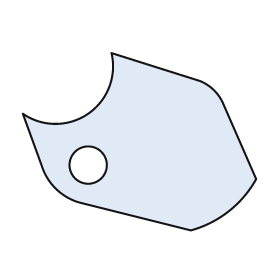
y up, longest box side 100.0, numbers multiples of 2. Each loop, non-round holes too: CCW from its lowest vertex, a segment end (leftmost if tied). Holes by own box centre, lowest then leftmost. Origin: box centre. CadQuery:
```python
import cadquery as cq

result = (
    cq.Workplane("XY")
    .moveTo(22.0, -38.0)
    .threePointArc((38.0, -30.0), (50.0, -16.0))
    .lineTo(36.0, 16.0)
    .threePointArc((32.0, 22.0), (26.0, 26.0))
    .lineTo(-12.0, 38.0)
    .threePointArc((-22.0, 12.0), (-50.0, 12.0))
    .lineTo(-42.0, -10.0)
    .threePointArc((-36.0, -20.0), (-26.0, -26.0))
    .close()
    .moveTo(-22.0, -10.0)
    .circle(8.0)
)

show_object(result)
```